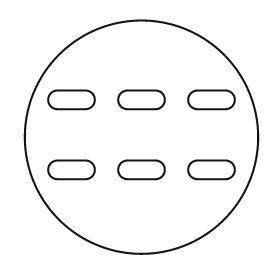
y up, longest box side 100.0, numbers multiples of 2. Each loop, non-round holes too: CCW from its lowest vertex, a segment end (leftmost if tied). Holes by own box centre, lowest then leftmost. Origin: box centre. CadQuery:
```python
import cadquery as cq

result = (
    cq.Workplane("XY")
    .moveTo(0.0, 0.0)
    .circle(50.0)
    .moveTo(-36.0, -18.0)
    .lineTo(-24.0, -18.0)
    .threePointArc((-20.0, -14.0), (-24.0, -10.0))
    .lineTo(-36.0, -10.0)
    .threePointArc((-40.0, -14.0), (-36.0, -18.0))
    .close()
    .moveTo(-6.0, -18.0)
    .lineTo(6.0, -18.0)
    .threePointArc((10.0, -14.0), (6.0, -10.0))
    .lineTo(-6.0, -10.0)
    .threePointArc((-10.0, -14.0), (-6.0, -18.0))
    .close()
    .moveTo(24.0, -18.0)
    .lineTo(36.0, -18.0)
    .threePointArc((40.0, -14.0), (36.0, -10.0))
    .lineTo(24.0, -10.0)
    .threePointArc((20.0, -14.0), (24.0, -18.0))
    .close()
    .moveTo(-36.0, 12.0)
    .lineTo(-24.0, 12.0)
    .threePointArc((-20.0, 16.0), (-24.0, 20.0))
    .lineTo(-36.0, 20.0)
    .threePointArc((-40.0, 16.0), (-36.0, 12.0))
    .close()
    .moveTo(-6.0, 12.0)
    .lineTo(6.0, 12.0)
    .threePointArc((10.0, 16.0), (6.0, 20.0))
    .lineTo(-6.0, 20.0)
    .threePointArc((-10.0, 16.0), (-6.0, 12.0))
    .close()
    .moveTo(24.0, 12.0)
    .lineTo(36.0, 12.0)
    .threePointArc((40.0, 16.0), (36.0, 20.0))
    .lineTo(24.0, 20.0)
    .threePointArc((20.0, 16.0), (24.0, 12.0))
    .close()
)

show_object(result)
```